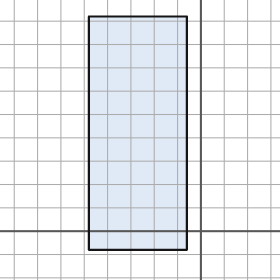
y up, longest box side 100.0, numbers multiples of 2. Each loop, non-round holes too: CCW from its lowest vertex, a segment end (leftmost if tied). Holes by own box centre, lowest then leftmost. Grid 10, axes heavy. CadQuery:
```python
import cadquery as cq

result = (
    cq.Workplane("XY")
    .moveTo(-48.0, -8.0)
    .lineTo(-6.0, -8.0)
    .lineTo(-6.0, 92.0)
    .lineTo(-48.0, 92.0)
    .close()
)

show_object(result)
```